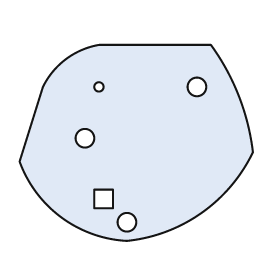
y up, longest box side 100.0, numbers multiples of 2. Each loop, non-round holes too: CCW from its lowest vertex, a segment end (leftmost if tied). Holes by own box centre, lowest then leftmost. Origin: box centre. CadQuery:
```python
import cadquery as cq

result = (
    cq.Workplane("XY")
    .moveTo(-4.0, -42.0)
    .threePointArc((28.0, -30.0), (50.0, -4.0))
    .threePointArc((44.0, 20.0), (32.0, 42.0))
    .lineTo(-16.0, 42.0)
    .threePointArc((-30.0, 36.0), (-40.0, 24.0))
    .lineTo(-50.0, -8.0)
    .threePointArc((-32.0, -32.0), (-4.0, -42.0))
    .close()
    .moveTo(-4.0, -34.0)
    .circle(4.0)
    .moveTo(-18.0, -28.0)
    .lineTo(-10.0, -28.0)
    .lineTo(-10.0, -20.0)
    .lineTo(-18.0, -20.0)
    .close()
    .moveTo(-22.0, 2.0)
    .circle(4.0)
    .moveTo(-16.0, 24.0)
    .circle(2.0)
    .moveTo(26.0, 24.0)
    .circle(4.0)
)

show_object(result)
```